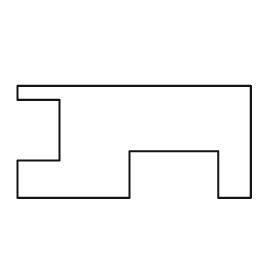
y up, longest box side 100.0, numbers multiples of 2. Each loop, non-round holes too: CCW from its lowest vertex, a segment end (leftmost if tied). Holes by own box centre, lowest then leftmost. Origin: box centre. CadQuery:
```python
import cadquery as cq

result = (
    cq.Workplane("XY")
    .moveTo(-50.0, -24.0)
    .lineTo(-2.0, -24.0)
    .lineTo(-2.0, -4.0)
    .lineTo(36.0, -4.0)
    .lineTo(36.0, -24.0)
    .lineTo(50.0, -24.0)
    .lineTo(50.0, 24.0)
    .lineTo(-50.0, 24.0)
    .lineTo(-50.0, 18.0)
    .lineTo(-32.0, 18.0)
    .lineTo(-32.0, -8.0)
    .lineTo(-50.0, -8.0)
    .close()
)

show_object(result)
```